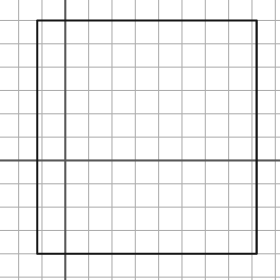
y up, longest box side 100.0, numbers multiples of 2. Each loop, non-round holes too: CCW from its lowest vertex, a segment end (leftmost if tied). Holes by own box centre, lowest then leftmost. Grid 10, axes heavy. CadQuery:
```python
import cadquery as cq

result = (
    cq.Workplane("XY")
    .moveTo(-12.0, -40.0)
    .lineTo(82.0, -40.0)
    .lineTo(82.0, 60.0)
    .lineTo(-12.0, 60.0)
    .close()
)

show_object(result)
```